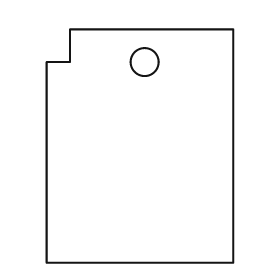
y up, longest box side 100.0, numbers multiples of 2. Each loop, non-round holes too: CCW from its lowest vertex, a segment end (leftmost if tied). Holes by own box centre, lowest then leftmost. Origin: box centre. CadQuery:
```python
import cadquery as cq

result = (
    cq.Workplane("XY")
    .moveTo(-40.0, -50.0)
    .lineTo(40.0, -50.0)
    .lineTo(40.0, 50.0)
    .lineTo(-30.0, 50.0)
    .lineTo(-30.0, 36.0)
    .lineTo(-40.0, 36.0)
    .close()
    .moveTo(2.0, 36.0)
    .circle(6.0)
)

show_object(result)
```